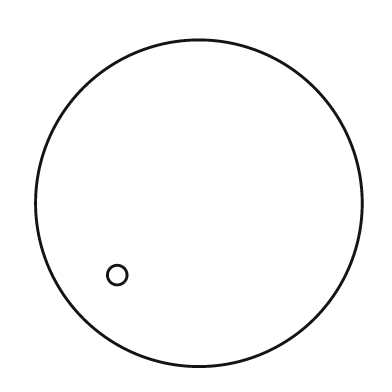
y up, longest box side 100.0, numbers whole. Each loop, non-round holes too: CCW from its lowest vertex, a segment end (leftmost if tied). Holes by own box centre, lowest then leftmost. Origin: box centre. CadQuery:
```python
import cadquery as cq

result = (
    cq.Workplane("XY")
    .moveTo(0.0, 0.0)
    .circle(50.0)
    .moveTo(-25.0, -22.0)
    .circle(3.0)
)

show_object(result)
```